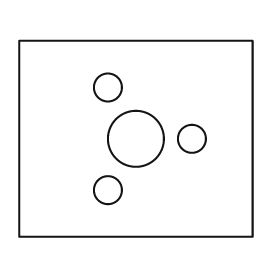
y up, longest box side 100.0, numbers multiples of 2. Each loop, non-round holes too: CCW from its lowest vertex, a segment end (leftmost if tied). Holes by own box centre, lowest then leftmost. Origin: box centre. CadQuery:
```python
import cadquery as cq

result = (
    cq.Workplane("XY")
    .moveTo(-50.0, -42.0)
    .lineTo(50.0, -42.0)
    .lineTo(50.0, 42.0)
    .lineTo(-50.0, 42.0)
    .close()
    .moveTo(-12.0, -22.0)
    .circle(6.0)
    .moveTo(0.0, 0.0)
    .circle(12.0)
    .moveTo(24.0, 0.0)
    .circle(6.0)
    .moveTo(-12.0, 22.0)
    .circle(6.0)
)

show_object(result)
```